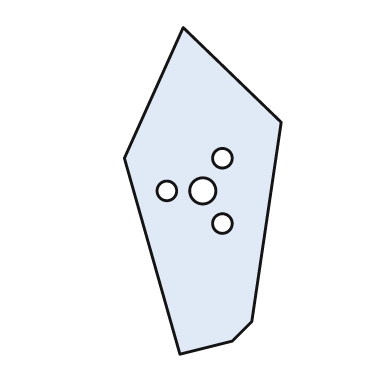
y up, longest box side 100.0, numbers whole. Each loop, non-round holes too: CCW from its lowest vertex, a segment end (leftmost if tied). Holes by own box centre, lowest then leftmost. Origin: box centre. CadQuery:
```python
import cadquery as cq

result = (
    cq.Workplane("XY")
    .moveTo(-7.0, -50.0)
    .lineTo(9.0, -46.0)
    .lineTo(15.0, -40.0)
    .lineTo(24.0, 21.0)
    .lineTo(-6.0, 50.0)
    .lineTo(-24.0, 10.0)
    .close()
    .moveTo(6.0, -10.0)
    .circle(3.0)
    .moveTo(-11.0, 0.0)
    .circle(3.0)
    .moveTo(0.0, 0.0)
    .circle(4.0)
    .moveTo(6.0, 10.0)
    .circle(3.0)
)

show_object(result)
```